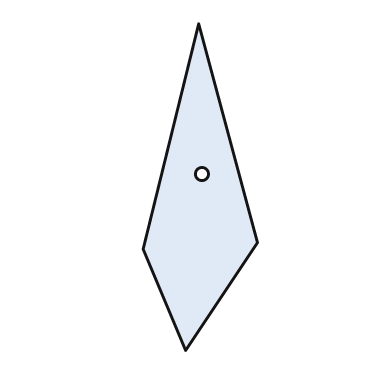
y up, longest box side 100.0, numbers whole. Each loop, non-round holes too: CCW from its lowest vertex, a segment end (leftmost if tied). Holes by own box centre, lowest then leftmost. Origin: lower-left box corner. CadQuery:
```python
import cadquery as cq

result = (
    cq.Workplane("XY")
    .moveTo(13.0, 0.0)
    .lineTo(35.0, 33.0)
    .lineTo(17.0, 100.0)
    .lineTo(0.0, 31.0)
    .close()
    .moveTo(18.0, 54.0)
    .circle(2.0)
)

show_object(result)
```